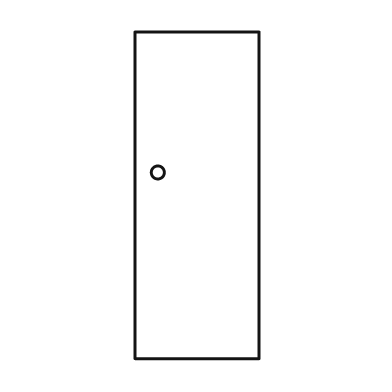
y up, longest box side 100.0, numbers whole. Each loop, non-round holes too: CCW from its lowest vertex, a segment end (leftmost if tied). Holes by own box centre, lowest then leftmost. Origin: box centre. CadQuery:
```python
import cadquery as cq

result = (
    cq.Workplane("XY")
    .moveTo(-19.0, -50.0)
    .lineTo(19.0, -50.0)
    .lineTo(19.0, 50.0)
    .lineTo(-19.0, 50.0)
    .close()
    .moveTo(-12.0, 7.0)
    .circle(2.0)
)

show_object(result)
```